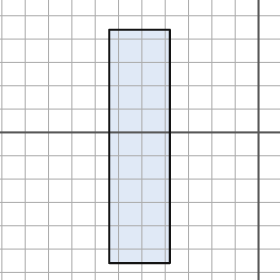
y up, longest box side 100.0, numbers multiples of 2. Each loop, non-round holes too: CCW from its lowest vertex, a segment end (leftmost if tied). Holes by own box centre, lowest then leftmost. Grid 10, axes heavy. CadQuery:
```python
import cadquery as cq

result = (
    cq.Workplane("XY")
    .moveTo(-64.0, -56.0)
    .lineTo(-38.0, -56.0)
    .lineTo(-38.0, 44.0)
    .lineTo(-64.0, 44.0)
    .close()
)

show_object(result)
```